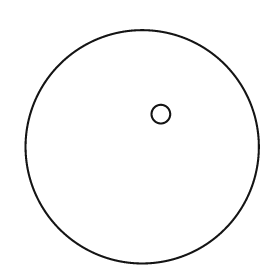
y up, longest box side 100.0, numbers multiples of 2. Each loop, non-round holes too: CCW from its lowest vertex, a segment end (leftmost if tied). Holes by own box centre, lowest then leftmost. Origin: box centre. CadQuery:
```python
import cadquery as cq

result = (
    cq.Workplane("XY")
    .moveTo(0.0, 0.0)
    .circle(50.0)
    .moveTo(8.0, 14.0)
    .circle(4.0)
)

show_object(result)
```